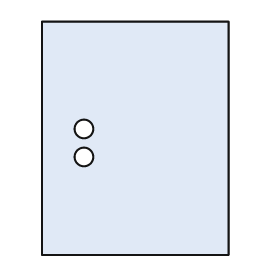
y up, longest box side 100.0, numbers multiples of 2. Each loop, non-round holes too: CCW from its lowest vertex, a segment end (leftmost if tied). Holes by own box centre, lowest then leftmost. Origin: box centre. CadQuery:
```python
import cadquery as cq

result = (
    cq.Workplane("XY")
    .moveTo(-40.0, -50.0)
    .lineTo(40.0, -50.0)
    .lineTo(40.0, 50.0)
    .lineTo(-40.0, 50.0)
    .close()
    .moveTo(-22.0, -8.0)
    .circle(4.0)
    .moveTo(-22.0, 4.0)
    .circle(4.0)
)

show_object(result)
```